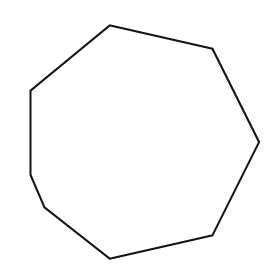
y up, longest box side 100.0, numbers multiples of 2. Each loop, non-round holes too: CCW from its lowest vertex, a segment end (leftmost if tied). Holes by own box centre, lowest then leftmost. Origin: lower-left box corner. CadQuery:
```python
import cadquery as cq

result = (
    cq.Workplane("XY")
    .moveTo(34.0, 0.0)
    .lineTo(78.0, 10.0)
    .lineTo(98.0, 50.0)
    .lineTo(78.0, 90.0)
    .lineTo(34.0, 100.0)
    .lineTo(0.0, 72.0)
    .lineTo(0.0, 36.0)
    .lineTo(6.0, 22.0)
    .close()
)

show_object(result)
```